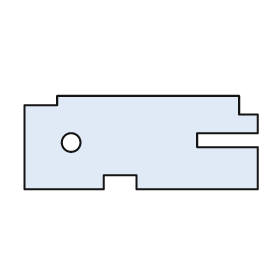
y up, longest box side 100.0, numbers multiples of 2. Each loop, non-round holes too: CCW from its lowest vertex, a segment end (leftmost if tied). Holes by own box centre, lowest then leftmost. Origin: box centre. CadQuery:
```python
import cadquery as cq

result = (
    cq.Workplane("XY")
    .moveTo(-50.0, -20.0)
    .lineTo(-16.0, -20.0)
    .lineTo(-16.0, -14.0)
    .lineTo(-2.0, -14.0)
    .lineTo(-2.0, -20.0)
    .lineTo(50.0, -20.0)
    .lineTo(50.0, -2.0)
    .lineTo(24.0, -2.0)
    .lineTo(24.0, 4.0)
    .lineTo(50.0, 4.0)
    .lineTo(50.0, 12.0)
    .lineTo(42.0, 12.0)
    .lineTo(42.0, 20.0)
    .lineTo(-36.0, 20.0)
    .lineTo(-36.0, 16.0)
    .lineTo(-50.0, 16.0)
    .close()
    .moveTo(-30.0, 0.0)
    .circle(4.0)
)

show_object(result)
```